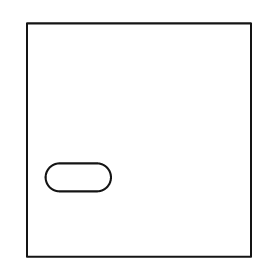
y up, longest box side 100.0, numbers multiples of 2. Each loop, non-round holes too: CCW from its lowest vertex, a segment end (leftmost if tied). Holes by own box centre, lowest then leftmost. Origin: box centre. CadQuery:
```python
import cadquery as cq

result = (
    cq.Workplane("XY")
    .moveTo(-48.0, -50.0)
    .lineTo(48.0, -50.0)
    .lineTo(48.0, 50.0)
    .lineTo(-48.0, 50.0)
    .close()
    .moveTo(-34.0, -22.0)
    .lineTo(-18.0, -22.0)
    .threePointArc((-12.0, -16.0), (-18.0, -10.0))
    .lineTo(-34.0, -10.0)
    .threePointArc((-40.0, -16.0), (-34.0, -22.0))
    .close()
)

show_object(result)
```